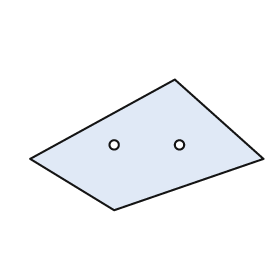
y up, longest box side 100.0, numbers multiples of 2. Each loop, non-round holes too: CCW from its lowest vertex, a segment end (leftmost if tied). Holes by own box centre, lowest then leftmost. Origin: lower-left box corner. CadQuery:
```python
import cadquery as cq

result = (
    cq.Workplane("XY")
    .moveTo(36.0, 0.0)
    .lineTo(100.0, 22.0)
    .lineTo(62.0, 56.0)
    .lineTo(0.0, 22.0)
    .close()
    .moveTo(36.0, 28.0)
    .circle(2.0)
    .moveTo(64.0, 28.0)
    .circle(2.0)
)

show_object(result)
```